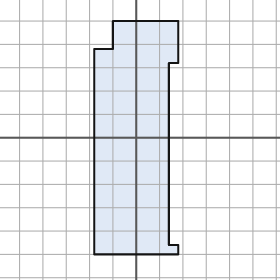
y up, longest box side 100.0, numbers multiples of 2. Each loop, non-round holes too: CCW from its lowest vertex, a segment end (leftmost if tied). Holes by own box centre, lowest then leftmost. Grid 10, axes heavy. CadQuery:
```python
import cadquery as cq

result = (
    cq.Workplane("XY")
    .moveTo(-18.0, -50.0)
    .lineTo(18.0, -50.0)
    .lineTo(18.0, -46.0)
    .lineTo(14.0, -46.0)
    .lineTo(14.0, 32.0)
    .lineTo(18.0, 32.0)
    .lineTo(18.0, 50.0)
    .lineTo(-10.0, 50.0)
    .lineTo(-10.0, 38.0)
    .lineTo(-18.0, 38.0)
    .close()
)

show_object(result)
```